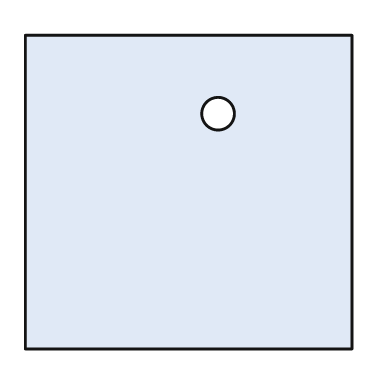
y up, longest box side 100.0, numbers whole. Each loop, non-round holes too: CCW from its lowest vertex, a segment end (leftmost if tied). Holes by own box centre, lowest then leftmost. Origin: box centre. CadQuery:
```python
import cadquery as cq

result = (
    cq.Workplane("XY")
    .moveTo(-50.0, -48.0)
    .lineTo(50.0, -48.0)
    .lineTo(50.0, 48.0)
    .lineTo(-50.0, 48.0)
    .close()
    .moveTo(9.0, 24.0)
    .circle(5.0)
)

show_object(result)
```